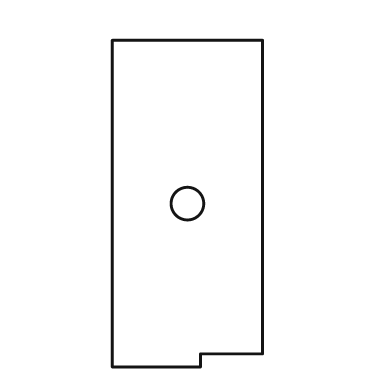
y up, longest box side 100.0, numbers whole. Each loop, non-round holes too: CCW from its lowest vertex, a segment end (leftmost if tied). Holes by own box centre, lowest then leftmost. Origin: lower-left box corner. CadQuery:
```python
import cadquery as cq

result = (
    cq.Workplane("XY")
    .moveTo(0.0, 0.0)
    .lineTo(27.0, 0.0)
    .lineTo(27.0, 4.0)
    .lineTo(46.0, 4.0)
    .lineTo(46.0, 100.0)
    .lineTo(0.0, 100.0)
    .close()
    .moveTo(23.0, 50.0)
    .circle(5.0)
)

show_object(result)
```